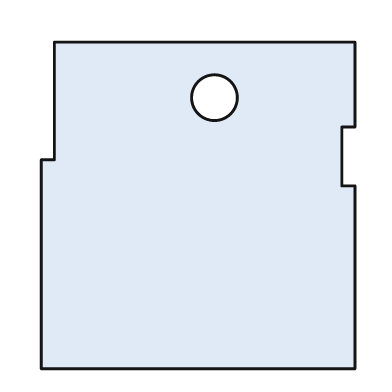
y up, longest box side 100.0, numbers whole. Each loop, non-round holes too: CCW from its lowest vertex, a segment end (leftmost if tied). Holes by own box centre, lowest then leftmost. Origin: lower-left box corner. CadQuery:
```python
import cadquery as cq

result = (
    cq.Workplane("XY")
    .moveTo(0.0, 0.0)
    .lineTo(96.0, 0.0)
    .lineTo(96.0, 56.0)
    .lineTo(92.0, 56.0)
    .lineTo(92.0, 74.0)
    .lineTo(96.0, 74.0)
    .lineTo(96.0, 100.0)
    .lineTo(4.0, 100.0)
    .lineTo(4.0, 64.0)
    .lineTo(0.0, 64.0)
    .close()
    .moveTo(53.0, 83.0)
    .circle(7.0)
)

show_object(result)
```